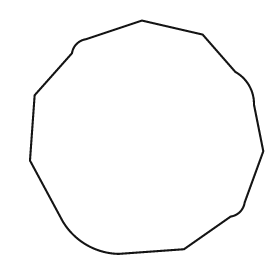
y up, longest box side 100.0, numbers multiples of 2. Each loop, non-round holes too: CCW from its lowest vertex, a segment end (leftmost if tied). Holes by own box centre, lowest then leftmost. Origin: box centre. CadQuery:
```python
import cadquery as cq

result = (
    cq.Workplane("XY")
    .moveTo(-12.0, -50.0)
    .lineTo(16.0, -48.0)
    .lineTo(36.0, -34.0)
    .threePointArc((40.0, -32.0), (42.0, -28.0))
    .lineTo(50.0, -6.0)
    .lineTo(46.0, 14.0)
    .threePointArc((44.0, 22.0), (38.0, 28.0))
    .lineTo(24.0, 44.0)
    .lineTo(-2.0, 50.0)
    .lineTo(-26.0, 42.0)
    .threePointArc((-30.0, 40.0), (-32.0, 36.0))
    .lineTo(-48.0, 18.0)
    .lineTo(-50.0, -10.0)
    .lineTo(-36.0, -36.0)
    .threePointArc((-26.0, -46.0), (-12.0, -50.0))
    .close()
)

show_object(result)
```